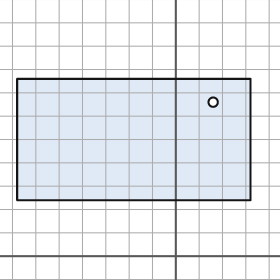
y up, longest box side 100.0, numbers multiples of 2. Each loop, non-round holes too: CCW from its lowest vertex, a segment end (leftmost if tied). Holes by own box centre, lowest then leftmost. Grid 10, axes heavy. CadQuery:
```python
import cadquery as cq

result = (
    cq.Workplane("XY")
    .moveTo(-68.0, 24.0)
    .lineTo(32.0, 24.0)
    .lineTo(32.0, 76.0)
    .lineTo(-68.0, 76.0)
    .close()
    .moveTo(16.0, 66.0)
    .circle(2.0)
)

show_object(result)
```